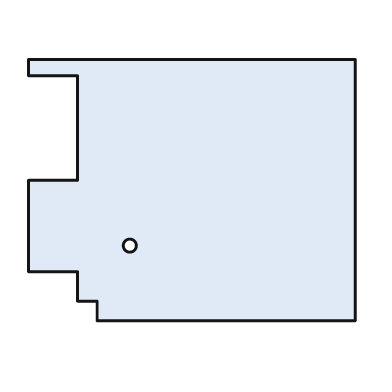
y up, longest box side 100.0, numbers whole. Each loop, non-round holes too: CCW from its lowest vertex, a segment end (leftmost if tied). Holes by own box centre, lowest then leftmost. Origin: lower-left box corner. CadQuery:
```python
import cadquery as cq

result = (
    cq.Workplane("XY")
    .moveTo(21.0, 0.0)
    .lineTo(100.0, 0.0)
    .lineTo(100.0, 80.0)
    .lineTo(0.0, 80.0)
    .lineTo(0.0, 75.0)
    .lineTo(15.0, 75.0)
    .lineTo(15.0, 43.0)
    .lineTo(0.0, 43.0)
    .lineTo(0.0, 15.0)
    .lineTo(15.0, 15.0)
    .lineTo(15.0, 6.0)
    .lineTo(21.0, 6.0)
    .close()
    .moveTo(31.0, 23.0)
    .circle(2.0)
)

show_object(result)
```